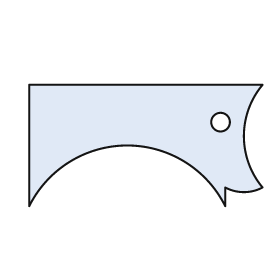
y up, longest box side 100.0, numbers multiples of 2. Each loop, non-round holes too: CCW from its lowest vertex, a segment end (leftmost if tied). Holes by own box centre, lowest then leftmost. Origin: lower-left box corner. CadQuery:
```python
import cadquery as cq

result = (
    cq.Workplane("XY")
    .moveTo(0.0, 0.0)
    .threePointArc((42.0, 26.0), (84.0, 0.0))
    .lineTo(84.0, 8.0)
    .threePointArc((92.0, 6.0), (100.0, 8.0))
    .threePointArc((92.0, 30.0), (100.0, 52.0))
    .lineTo(0.0, 52.0)
    .close()
    .moveTo(82.0, 36.0)
    .circle(4.0)
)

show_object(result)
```